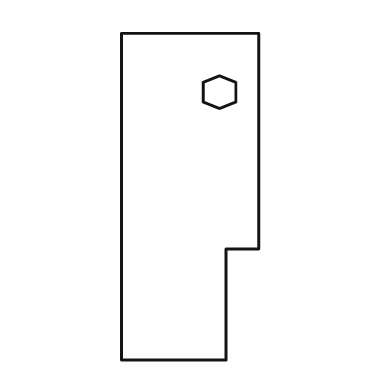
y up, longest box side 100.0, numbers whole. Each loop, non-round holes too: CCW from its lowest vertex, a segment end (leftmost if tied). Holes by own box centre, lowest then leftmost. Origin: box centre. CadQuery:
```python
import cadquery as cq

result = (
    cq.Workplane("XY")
    .moveTo(-21.0, -50.0)
    .lineTo(11.0, -50.0)
    .lineTo(11.0, -16.0)
    .lineTo(21.0, -16.0)
    .lineTo(21.0, 50.0)
    .lineTo(-21.0, 50.0)
    .close()
    .moveTo(9.0, 27.0)
    .lineTo(14.0, 29.0)
    .lineTo(14.0, 35.0)
    .lineTo(9.0, 37.0)
    .lineTo(4.0, 35.0)
    .lineTo(4.0, 29.0)
    .close()
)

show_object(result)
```